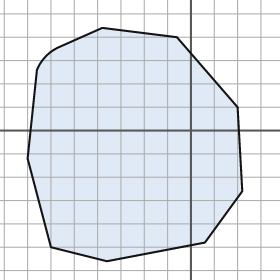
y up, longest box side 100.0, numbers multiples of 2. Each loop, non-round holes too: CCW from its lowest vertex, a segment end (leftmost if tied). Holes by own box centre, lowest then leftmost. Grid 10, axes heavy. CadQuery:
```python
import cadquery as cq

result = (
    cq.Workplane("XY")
    .moveTo(-36.0, -56.0)
    .lineTo(6.0, -48.0)
    .lineTo(22.0, -26.0)
    .lineTo(20.0, 10.0)
    .lineTo(-6.0, 40.0)
    .lineTo(-38.0, 44.0)
    .lineTo(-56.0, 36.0)
    .threePointArc((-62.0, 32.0), (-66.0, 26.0))
    .lineTo(-70.0, -12.0)
    .lineTo(-60.0, -50.0)
    .close()
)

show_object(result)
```